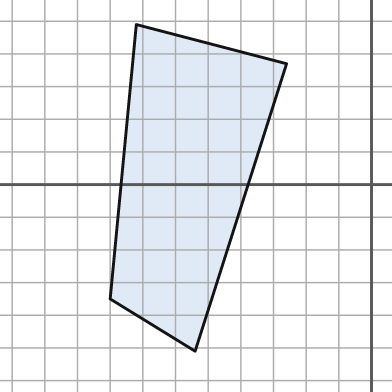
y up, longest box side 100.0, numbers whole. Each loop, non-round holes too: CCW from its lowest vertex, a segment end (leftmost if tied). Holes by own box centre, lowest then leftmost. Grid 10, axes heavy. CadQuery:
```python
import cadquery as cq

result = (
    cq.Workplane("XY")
    .moveTo(-54.0, -51.0)
    .lineTo(-26.0, 37.0)
    .lineTo(-72.0, 49.0)
    .lineTo(-80.0, -35.0)
    .close()
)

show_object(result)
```